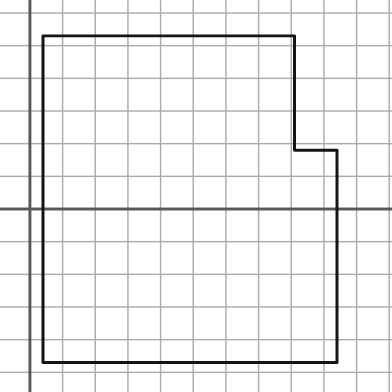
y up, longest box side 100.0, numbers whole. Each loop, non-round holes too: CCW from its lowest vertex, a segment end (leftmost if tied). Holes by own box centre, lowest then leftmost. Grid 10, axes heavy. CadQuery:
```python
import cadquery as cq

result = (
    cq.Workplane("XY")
    .moveTo(4.0, -47.0)
    .lineTo(94.0, -47.0)
    .lineTo(94.0, 18.0)
    .lineTo(81.0, 18.0)
    .lineTo(81.0, 53.0)
    .lineTo(4.0, 53.0)
    .close()
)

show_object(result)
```